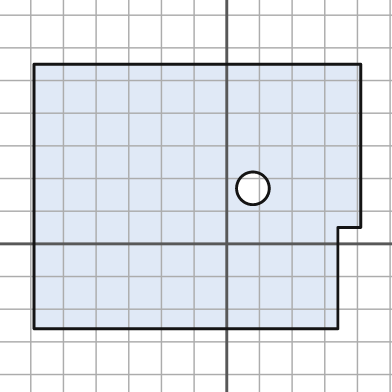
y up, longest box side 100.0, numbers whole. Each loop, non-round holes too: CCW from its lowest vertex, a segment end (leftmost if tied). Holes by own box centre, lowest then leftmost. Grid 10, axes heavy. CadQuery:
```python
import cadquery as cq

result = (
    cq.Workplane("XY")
    .moveTo(-59.0, -26.0)
    .lineTo(34.0, -26.0)
    .lineTo(34.0, 5.0)
    .lineTo(41.0, 5.0)
    .lineTo(41.0, 55.0)
    .lineTo(-59.0, 55.0)
    .close()
    .moveTo(8.0, 17.0)
    .circle(5.0)
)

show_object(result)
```